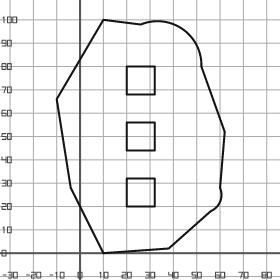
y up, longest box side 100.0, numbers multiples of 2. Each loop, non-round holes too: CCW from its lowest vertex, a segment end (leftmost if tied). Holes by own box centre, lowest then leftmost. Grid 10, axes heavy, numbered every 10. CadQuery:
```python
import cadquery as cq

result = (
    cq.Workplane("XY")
    .moveTo(10.0, 0.0)
    .lineTo(38.0, 2.0)
    .lineTo(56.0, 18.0)
    .threePointArc((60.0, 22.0), (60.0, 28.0))
    .lineTo(62.0, 52.0)
    .lineTo(52.0, 80.0)
    .threePointArc((44.0, 96.0), (26.0, 98.0))
    .lineTo(10.0, 100.0)
    .lineTo(-10.0, 66.0)
    .lineTo(-4.0, 28.0)
    .close()
    .moveTo(20.0, 20.0)
    .lineTo(32.0, 20.0)
    .lineTo(32.0, 32.0)
    .lineTo(20.0, 32.0)
    .close()
    .moveTo(20.0, 44.0)
    .lineTo(32.0, 44.0)
    .lineTo(32.0, 56.0)
    .lineTo(20.0, 56.0)
    .close()
    .moveTo(20.0, 68.0)
    .lineTo(32.0, 68.0)
    .lineTo(32.0, 80.0)
    .lineTo(20.0, 80.0)
    .close()
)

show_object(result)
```